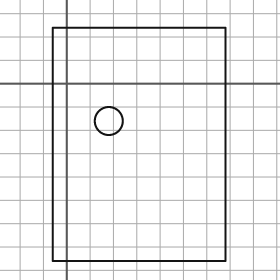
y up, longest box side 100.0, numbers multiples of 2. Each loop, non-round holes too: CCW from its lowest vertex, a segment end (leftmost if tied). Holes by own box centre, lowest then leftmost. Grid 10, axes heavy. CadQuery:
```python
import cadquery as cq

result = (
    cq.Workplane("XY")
    .moveTo(-6.0, -76.0)
    .lineTo(68.0, -76.0)
    .lineTo(68.0, 24.0)
    .lineTo(-6.0, 24.0)
    .close()
    .moveTo(18.0, -16.0)
    .circle(6.0)
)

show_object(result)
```